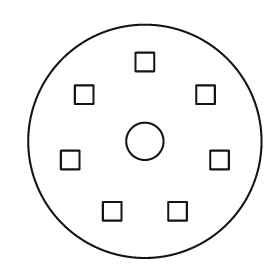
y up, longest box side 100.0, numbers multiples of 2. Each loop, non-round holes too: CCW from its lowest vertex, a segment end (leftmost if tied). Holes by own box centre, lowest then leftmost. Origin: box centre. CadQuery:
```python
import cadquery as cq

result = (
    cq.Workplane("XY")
    .moveTo(0.0, 0.0)
    .circle(50.0)
    .moveTo(-18.0, -34.0)
    .lineTo(-10.0, -34.0)
    .lineTo(-10.0, -26.0)
    .lineTo(-18.0, -26.0)
    .close()
    .moveTo(10.0, -34.0)
    .lineTo(18.0, -34.0)
    .lineTo(18.0, -26.0)
    .lineTo(10.0, -26.0)
    .close()
    .moveTo(-36.0, -12.0)
    .lineTo(-28.0, -12.0)
    .lineTo(-28.0, -4.0)
    .lineTo(-36.0, -4.0)
    .close()
    .moveTo(28.0, -12.0)
    .lineTo(36.0, -12.0)
    .lineTo(36.0, -4.0)
    .lineTo(28.0, -4.0)
    .close()
    .moveTo(0.0, 0.0)
    .circle(8.0)
    .moveTo(-30.0, 16.0)
    .lineTo(-22.0, 16.0)
    .lineTo(-22.0, 24.0)
    .lineTo(-30.0, 24.0)
    .close()
    .moveTo(22.0, 16.0)
    .lineTo(30.0, 16.0)
    .lineTo(30.0, 24.0)
    .lineTo(22.0, 24.0)
    .close()
    .moveTo(-4.0, 30.0)
    .lineTo(4.0, 30.0)
    .lineTo(4.0, 38.0)
    .lineTo(-4.0, 38.0)
    .close()
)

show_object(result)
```